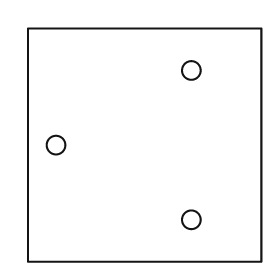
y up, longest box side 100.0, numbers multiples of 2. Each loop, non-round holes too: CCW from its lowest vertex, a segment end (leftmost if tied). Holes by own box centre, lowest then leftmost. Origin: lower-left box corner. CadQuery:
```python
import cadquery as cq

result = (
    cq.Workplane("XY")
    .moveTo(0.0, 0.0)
    .lineTo(100.0, 0.0)
    .lineTo(100.0, 100.0)
    .lineTo(0.0, 100.0)
    .close()
    .moveTo(70.0, 18.0)
    .circle(4.0)
    .moveTo(12.0, 50.0)
    .circle(4.0)
    .moveTo(70.0, 82.0)
    .circle(4.0)
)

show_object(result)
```